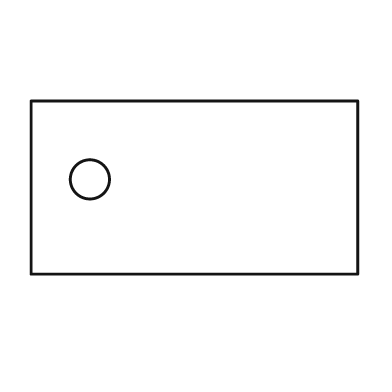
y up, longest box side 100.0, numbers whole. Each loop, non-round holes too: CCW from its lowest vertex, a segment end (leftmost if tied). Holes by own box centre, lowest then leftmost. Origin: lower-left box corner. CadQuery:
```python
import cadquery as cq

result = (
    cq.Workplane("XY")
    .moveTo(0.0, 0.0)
    .lineTo(100.0, 0.0)
    .lineTo(100.0, 53.0)
    .lineTo(0.0, 53.0)
    .close()
    .moveTo(18.0, 29.0)
    .circle(6.0)
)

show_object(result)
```